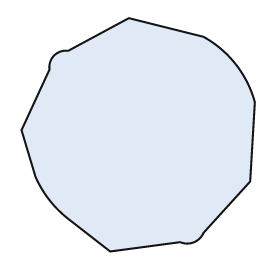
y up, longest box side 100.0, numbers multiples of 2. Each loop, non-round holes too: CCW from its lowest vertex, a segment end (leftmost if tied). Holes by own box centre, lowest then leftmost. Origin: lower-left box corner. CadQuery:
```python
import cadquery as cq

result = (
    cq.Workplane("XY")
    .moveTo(38.0, 0.0)
    .lineTo(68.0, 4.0)
    .threePointArc((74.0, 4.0), (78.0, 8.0))
    .lineTo(98.0, 30.0)
    .lineTo(100.0, 64.0)
    .threePointArc((92.0, 80.0), (78.0, 92.0))
    .lineTo(46.0, 100.0)
    .lineTo(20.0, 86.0)
    .threePointArc((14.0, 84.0), (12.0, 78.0))
    .lineTo(0.0, 52.0)
    .lineTo(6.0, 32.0)
    .threePointArc((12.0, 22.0), (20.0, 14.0))
    .close()
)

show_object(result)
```